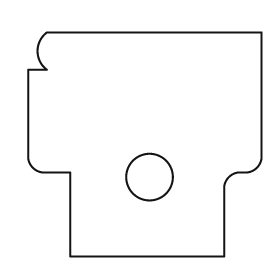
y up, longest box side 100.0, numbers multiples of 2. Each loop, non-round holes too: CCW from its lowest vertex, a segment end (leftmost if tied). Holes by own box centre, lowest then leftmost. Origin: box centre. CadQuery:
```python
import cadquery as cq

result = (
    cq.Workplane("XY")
    .moveTo(-32.0, -48.0)
    .lineTo(34.0, -48.0)
    .lineTo(34.0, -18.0)
    .threePointArc((36.0, -14.0), (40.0, -12.0))
    .lineTo(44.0, -12.0)
    .threePointArc((48.0, -10.0), (50.0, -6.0))
    .lineTo(50.0, 48.0)
    .lineTo(-42.0, 48.0)
    .threePointArc((-46.0, 40.0), (-42.0, 32.0))
    .lineTo(-50.0, 32.0)
    .lineTo(-50.0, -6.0)
    .threePointArc((-48.0, -10.0), (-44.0, -12.0))
    .lineTo(-32.0, -12.0)
    .close()
    .moveTo(2.0, -14.0)
    .circle(10.0)
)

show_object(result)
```